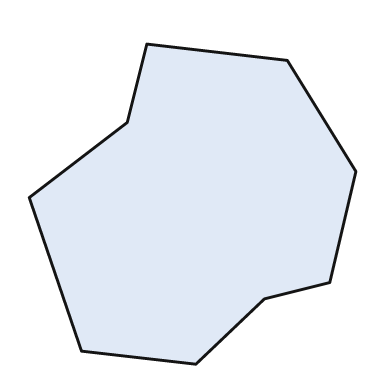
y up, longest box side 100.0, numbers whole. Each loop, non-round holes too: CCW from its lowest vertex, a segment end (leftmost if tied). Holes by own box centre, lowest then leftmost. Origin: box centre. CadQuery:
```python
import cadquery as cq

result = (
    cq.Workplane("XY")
    .moveTo(1.0, -49.0)
    .lineTo(22.0, -29.0)
    .lineTo(42.0, -24.0)
    .lineTo(50.0, 10.0)
    .lineTo(29.0, 44.0)
    .lineTo(-14.0, 49.0)
    .lineTo(-20.0, 25.0)
    .lineTo(-50.0, 2.0)
    .lineTo(-34.0, -45.0)
    .close()
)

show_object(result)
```